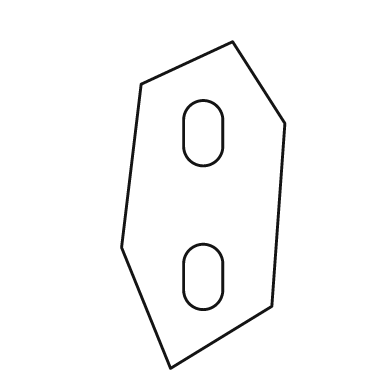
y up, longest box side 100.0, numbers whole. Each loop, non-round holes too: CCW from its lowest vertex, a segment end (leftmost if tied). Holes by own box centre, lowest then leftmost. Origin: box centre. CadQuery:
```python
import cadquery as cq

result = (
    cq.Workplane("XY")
    .moveTo(-10.0, -50.0)
    .lineTo(21.0, -31.0)
    .lineTo(25.0, 25.0)
    .lineTo(9.0, 50.0)
    .lineTo(-19.0, 37.0)
    .lineTo(-25.0, -13.0)
    .close()
    .moveTo(-6.0, -26.0)
    .threePointArc((0.0, -32.0), (6.0, -26.0))
    .lineTo(6.0, -18.0)
    .threePointArc((0.0, -12.0), (-6.0, -18.0))
    .close()
    .moveTo(-6.0, 18.0)
    .threePointArc((0.0, 12.0), (6.0, 18.0))
    .lineTo(6.0, 26.0)
    .threePointArc((0.0, 32.0), (-6.0, 26.0))
    .close()
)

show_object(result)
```